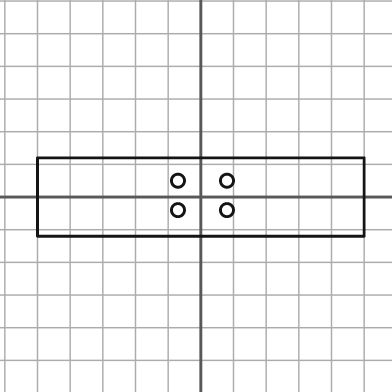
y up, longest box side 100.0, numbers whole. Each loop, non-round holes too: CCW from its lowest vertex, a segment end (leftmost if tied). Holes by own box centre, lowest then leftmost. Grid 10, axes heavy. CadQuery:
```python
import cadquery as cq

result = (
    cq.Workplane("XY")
    .moveTo(-50.0, -12.0)
    .lineTo(50.0, -12.0)
    .lineTo(50.0, 12.0)
    .lineTo(-50.0, 12.0)
    .close()
    .moveTo(-7.0, -4.0)
    .circle(2.0)
    .moveTo(8.0, -4.0)
    .circle(2.0)
    .moveTo(-7.0, 5.0)
    .circle(2.0)
    .moveTo(8.0, 5.0)
    .circle(2.0)
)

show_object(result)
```